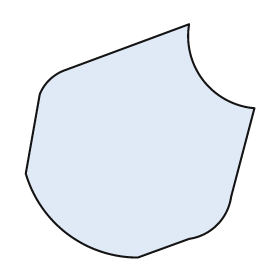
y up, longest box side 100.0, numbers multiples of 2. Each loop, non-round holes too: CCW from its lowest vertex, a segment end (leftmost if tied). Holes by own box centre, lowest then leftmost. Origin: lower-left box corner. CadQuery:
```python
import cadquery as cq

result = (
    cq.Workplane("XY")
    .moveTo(48.0, 0.0)
    .lineTo(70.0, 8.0)
    .threePointArc((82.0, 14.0), (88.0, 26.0))
    .lineTo(98.0, 64.0)
    .threePointArc((76.0, 76.0), (70.0, 100.0))
    .lineTo(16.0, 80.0)
    .threePointArc((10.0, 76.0), (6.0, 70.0))
    .lineTo(0.0, 36.0)
    .threePointArc((18.0, 10.0), (48.0, 0.0))
    .close()
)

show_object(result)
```